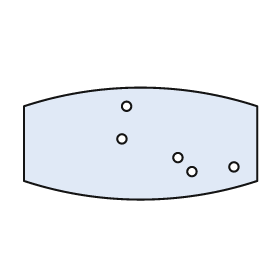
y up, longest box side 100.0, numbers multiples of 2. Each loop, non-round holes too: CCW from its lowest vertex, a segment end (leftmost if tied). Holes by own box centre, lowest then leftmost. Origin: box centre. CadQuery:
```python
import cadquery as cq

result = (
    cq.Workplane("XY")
    .moveTo(-50.0, -16.0)
    .threePointArc((0.0, -24.0), (50.0, -16.0))
    .lineTo(50.0, 16.0)
    .threePointArc((0.0, 24.0), (-50.0, 16.0))
    .close()
    .moveTo(22.0, -12.0)
    .circle(2.0)
    .moveTo(40.0, -10.0)
    .circle(2.0)
    .moveTo(16.0, -6.0)
    .circle(2.0)
    .moveTo(-8.0, 2.0)
    .circle(2.0)
    .moveTo(-6.0, 16.0)
    .circle(2.0)
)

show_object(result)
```